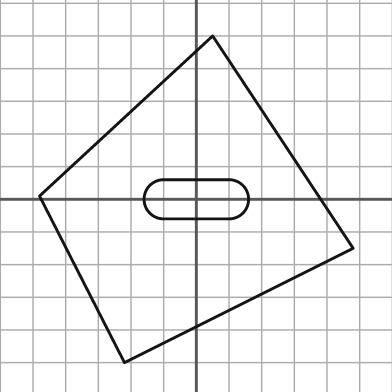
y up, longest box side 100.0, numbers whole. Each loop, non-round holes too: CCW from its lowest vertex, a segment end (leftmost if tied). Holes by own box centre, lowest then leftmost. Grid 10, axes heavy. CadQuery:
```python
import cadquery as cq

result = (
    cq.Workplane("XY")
    .moveTo(-22.0, -50.0)
    .lineTo(48.0, -15.0)
    .lineTo(5.0, 50.0)
    .lineTo(-48.0, 1.0)
    .close()
    .moveTo(-10.0, -6.0)
    .lineTo(10.0, -6.0)
    .threePointArc((16.0, 0.0), (10.0, 6.0))
    .lineTo(-10.0, 6.0)
    .threePointArc((-16.0, 0.0), (-10.0, -6.0))
    .close()
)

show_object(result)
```